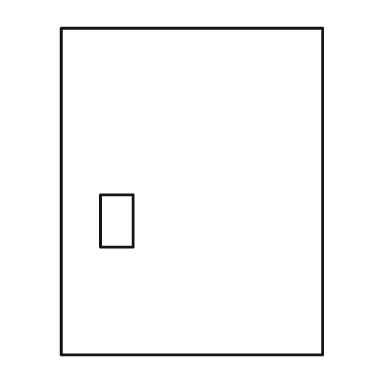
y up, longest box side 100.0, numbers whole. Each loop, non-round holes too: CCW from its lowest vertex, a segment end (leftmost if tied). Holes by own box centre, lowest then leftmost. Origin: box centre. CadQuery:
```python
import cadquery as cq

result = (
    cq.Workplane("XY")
    .moveTo(-40.0, -50.0)
    .lineTo(40.0, -50.0)
    .lineTo(40.0, 50.0)
    .lineTo(-40.0, 50.0)
    .close()
    .moveTo(-28.0, -17.0)
    .lineTo(-18.0, -17.0)
    .lineTo(-18.0, -1.0)
    .lineTo(-28.0, -1.0)
    .close()
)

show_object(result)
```